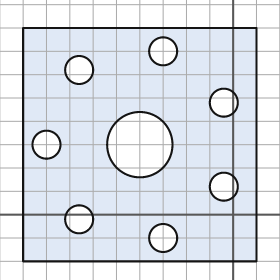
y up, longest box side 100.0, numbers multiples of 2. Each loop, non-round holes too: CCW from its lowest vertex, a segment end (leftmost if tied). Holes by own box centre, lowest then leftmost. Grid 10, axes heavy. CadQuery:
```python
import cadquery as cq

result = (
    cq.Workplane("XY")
    .moveTo(-90.0, -20.0)
    .lineTo(10.0, -20.0)
    .lineTo(10.0, 80.0)
    .lineTo(-90.0, 80.0)
    .close()
    .moveTo(-30.0, -10.0)
    .circle(6.0)
    .moveTo(-66.0, -2.0)
    .circle(6.0)
    .moveTo(-4.0, 12.0)
    .circle(6.0)
    .moveTo(-80.0, 30.0)
    .circle(6.0)
    .moveTo(-40.0, 30.0)
    .circle(14.0)
    .moveTo(-4.0, 48.0)
    .circle(6.0)
    .moveTo(-66.0, 62.0)
    .circle(6.0)
    .moveTo(-30.0, 70.0)
    .circle(6.0)
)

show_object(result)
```